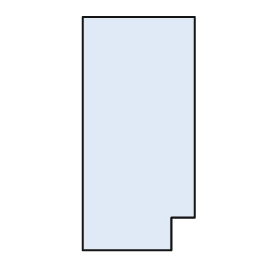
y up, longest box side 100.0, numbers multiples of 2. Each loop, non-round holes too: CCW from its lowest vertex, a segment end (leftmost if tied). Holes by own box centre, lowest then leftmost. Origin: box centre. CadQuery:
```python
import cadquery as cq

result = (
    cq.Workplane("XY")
    .moveTo(-24.0, -50.0)
    .lineTo(14.0, -50.0)
    .lineTo(14.0, -36.0)
    .lineTo(24.0, -36.0)
    .lineTo(24.0, 50.0)
    .lineTo(-24.0, 50.0)
    .close()
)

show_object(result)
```